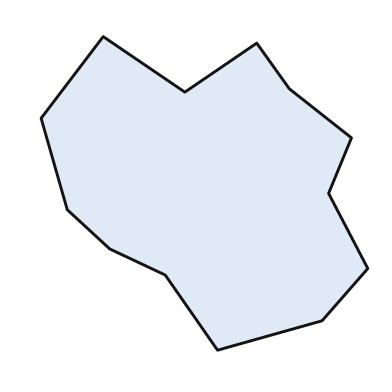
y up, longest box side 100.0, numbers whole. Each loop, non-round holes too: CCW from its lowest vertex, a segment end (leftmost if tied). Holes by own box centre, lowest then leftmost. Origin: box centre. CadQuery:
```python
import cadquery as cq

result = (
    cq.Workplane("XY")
    .moveTo(4.0, -48.0)
    .lineTo(36.0, -39.0)
    .lineTo(50.0, -23.0)
    .lineTo(38.0, 0.0)
    .lineTo(45.0, 17.0)
    .lineTo(26.0, 32.0)
    .lineTo(16.0, 46.0)
    .lineTo(-6.0, 31.0)
    .lineTo(-31.0, 48.0)
    .lineTo(-50.0, 23.0)
    .lineTo(-42.0, -5.0)
    .lineTo(-29.0, -17.0)
    .lineTo(-12.0, -25.0)
    .close()
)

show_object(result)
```